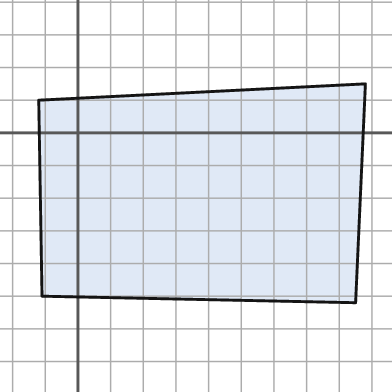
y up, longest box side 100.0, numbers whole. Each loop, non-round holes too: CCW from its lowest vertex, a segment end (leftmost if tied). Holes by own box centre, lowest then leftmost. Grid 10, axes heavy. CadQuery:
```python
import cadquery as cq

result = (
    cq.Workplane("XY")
    .moveTo(85.0, -52.0)
    .lineTo(88.0, 15.0)
    .lineTo(-12.0, 10.0)
    .lineTo(-11.0, -50.0)
    .close()
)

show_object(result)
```